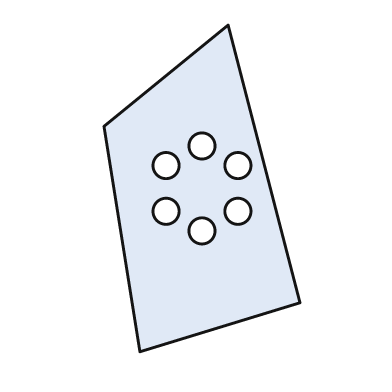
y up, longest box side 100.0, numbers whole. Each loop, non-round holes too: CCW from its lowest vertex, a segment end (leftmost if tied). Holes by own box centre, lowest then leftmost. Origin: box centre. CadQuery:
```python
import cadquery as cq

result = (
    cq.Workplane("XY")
    .moveTo(-19.0, -50.0)
    .lineTo(30.0, -35.0)
    .lineTo(8.0, 50.0)
    .lineTo(-30.0, 19.0)
    .close()
    .moveTo(0.0, -13.0)
    .circle(4.0)
    .moveTo(-11.0, -7.0)
    .circle(4.0)
    .moveTo(11.0, -7.0)
    .circle(4.0)
    .moveTo(-11.0, 7.0)
    .circle(4.0)
    .moveTo(11.0, 7.0)
    .circle(4.0)
    .moveTo(0.0, 13.0)
    .circle(4.0)
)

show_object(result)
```